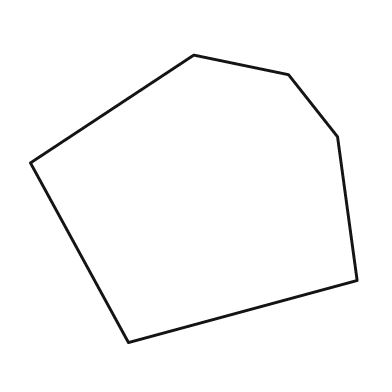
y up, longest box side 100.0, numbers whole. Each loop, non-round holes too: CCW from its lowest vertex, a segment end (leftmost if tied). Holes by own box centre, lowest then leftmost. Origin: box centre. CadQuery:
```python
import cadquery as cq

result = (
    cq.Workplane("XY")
    .moveTo(-20.0, -44.0)
    .lineTo(50.0, -25.0)
    .lineTo(44.0, 19.0)
    .lineTo(29.0, 38.0)
    .lineTo(0.0, 44.0)
    .lineTo(-50.0, 11.0)
    .close()
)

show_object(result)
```